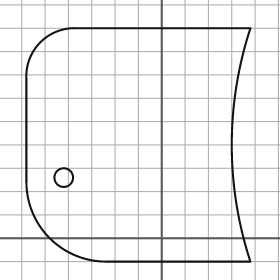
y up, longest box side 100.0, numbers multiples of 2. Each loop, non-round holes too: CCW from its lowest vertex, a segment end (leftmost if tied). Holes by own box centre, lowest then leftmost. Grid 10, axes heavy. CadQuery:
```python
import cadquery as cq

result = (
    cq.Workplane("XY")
    .moveTo(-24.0, -10.0)
    .lineTo(38.0, -10.0)
    .threePointArc((30.0, 40.0), (38.0, 90.0))
    .lineTo(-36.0, 90.0)
    .threePointArc((-52.0, 84.0), (-58.0, 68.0))
    .lineTo(-58.0, 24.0)
    .threePointArc((-48.0, 0.0), (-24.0, -10.0))
    .close()
    .moveTo(-42.0, 26.0)
    .circle(4.0)
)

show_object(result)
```